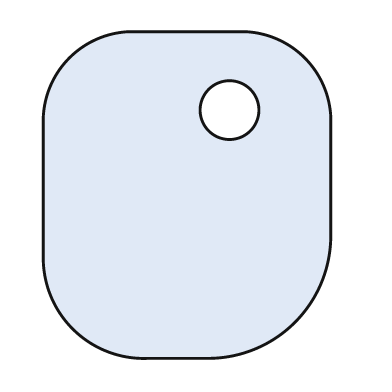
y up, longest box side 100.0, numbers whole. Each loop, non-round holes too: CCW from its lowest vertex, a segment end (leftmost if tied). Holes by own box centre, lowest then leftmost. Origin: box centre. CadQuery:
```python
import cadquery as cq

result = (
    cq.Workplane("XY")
    .moveTo(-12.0, -50.0)
    .lineTo(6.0, -50.0)
    .threePointArc((33.0, -39.0), (44.0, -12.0))
    .lineTo(44.0, 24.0)
    .threePointArc((36.0, 42.0), (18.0, 50.0))
    .lineTo(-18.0, 50.0)
    .threePointArc((-36.0, 42.0), (-44.0, 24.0))
    .lineTo(-44.0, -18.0)
    .threePointArc((-35.0, -41.0), (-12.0, -50.0))
    .close()
    .moveTo(13.0, 26.0)
    .circle(9.0)
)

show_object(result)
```